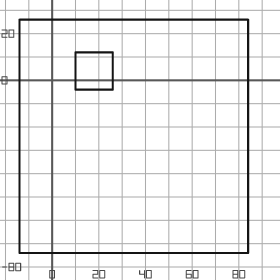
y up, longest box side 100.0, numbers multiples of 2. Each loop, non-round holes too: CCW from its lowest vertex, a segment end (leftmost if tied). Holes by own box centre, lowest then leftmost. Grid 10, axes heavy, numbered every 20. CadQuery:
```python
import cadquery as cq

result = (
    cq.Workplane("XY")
    .moveTo(-14.0, -74.0)
    .lineTo(84.0, -74.0)
    .lineTo(84.0, 26.0)
    .lineTo(-14.0, 26.0)
    .close()
    .moveTo(10.0, -4.0)
    .lineTo(26.0, -4.0)
    .lineTo(26.0, 12.0)
    .lineTo(10.0, 12.0)
    .close()
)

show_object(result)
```